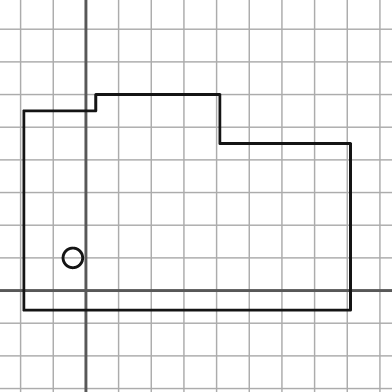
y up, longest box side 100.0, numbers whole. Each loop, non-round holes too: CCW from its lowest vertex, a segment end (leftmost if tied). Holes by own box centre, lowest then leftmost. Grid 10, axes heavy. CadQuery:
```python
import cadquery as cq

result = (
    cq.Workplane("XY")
    .moveTo(-19.0, -6.0)
    .lineTo(81.0, -6.0)
    .lineTo(81.0, 45.0)
    .lineTo(41.0, 45.0)
    .lineTo(41.0, 60.0)
    .lineTo(3.0, 60.0)
    .lineTo(3.0, 55.0)
    .lineTo(-19.0, 55.0)
    .close()
    .moveTo(-4.0, 10.0)
    .circle(3.0)
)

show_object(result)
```